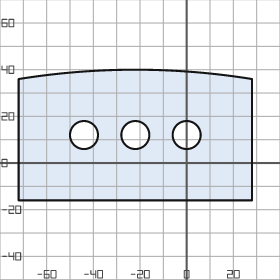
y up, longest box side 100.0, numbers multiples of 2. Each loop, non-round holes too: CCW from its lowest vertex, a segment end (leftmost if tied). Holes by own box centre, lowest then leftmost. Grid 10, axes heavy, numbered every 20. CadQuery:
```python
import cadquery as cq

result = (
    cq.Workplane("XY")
    .moveTo(-72.0, -16.0)
    .lineTo(28.0, -16.0)
    .lineTo(28.0, 36.0)
    .threePointArc((-22.0, 40.0), (-72.0, 36.0))
    .close()
    .moveTo(-44.0, 12.0)
    .circle(6.0)
    .moveTo(-22.0, 12.0)
    .circle(6.0)
    .moveTo(0.0, 12.0)
    .circle(6.0)
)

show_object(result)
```